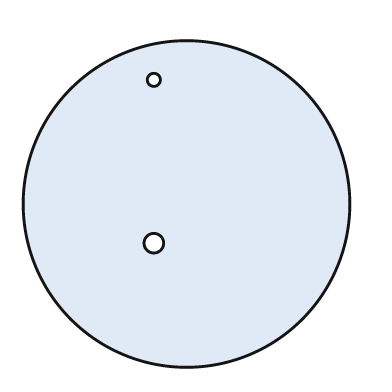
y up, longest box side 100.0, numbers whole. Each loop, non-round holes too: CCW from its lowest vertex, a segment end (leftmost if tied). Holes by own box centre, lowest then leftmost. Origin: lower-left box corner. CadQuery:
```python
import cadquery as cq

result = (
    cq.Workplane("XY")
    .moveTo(50.0, 50.0)
    .circle(50.0)
    .moveTo(40.0, 38.0)
    .circle(3.0)
    .moveTo(40.0, 88.0)
    .circle(2.0)
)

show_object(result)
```